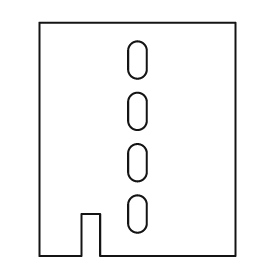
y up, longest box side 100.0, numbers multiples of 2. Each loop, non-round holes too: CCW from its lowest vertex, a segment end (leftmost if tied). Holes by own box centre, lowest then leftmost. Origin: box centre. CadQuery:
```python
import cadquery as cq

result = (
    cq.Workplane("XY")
    .moveTo(-42.0, -50.0)
    .lineTo(-24.0, -50.0)
    .lineTo(-24.0, -32.0)
    .lineTo(-16.0, -32.0)
    .lineTo(-16.0, -50.0)
    .lineTo(42.0, -50.0)
    .lineTo(42.0, 50.0)
    .lineTo(-42.0, 50.0)
    .close()
    .moveTo(-4.0, -36.0)
    .threePointArc((0.0, -40.0), (4.0, -36.0))
    .lineTo(4.0, -28.0)
    .threePointArc((0.0, -24.0), (-4.0, -28.0))
    .close()
    .moveTo(-4.0, -14.0)
    .threePointArc((0.0, -18.0), (4.0, -14.0))
    .lineTo(4.0, -6.0)
    .threePointArc((0.0, -2.0), (-4.0, -6.0))
    .close()
    .moveTo(-4.0, 8.0)
    .threePointArc((0.0, 4.0), (4.0, 8.0))
    .lineTo(4.0, 16.0)
    .threePointArc((0.0, 20.0), (-4.0, 16.0))
    .close()
    .moveTo(-4.0, 30.0)
    .threePointArc((0.0, 26.0), (4.0, 30.0))
    .lineTo(4.0, 38.0)
    .threePointArc((0.0, 42.0), (-4.0, 38.0))
    .close()
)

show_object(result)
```